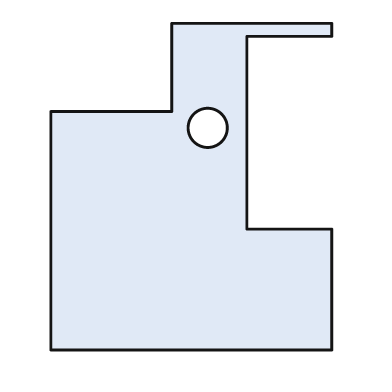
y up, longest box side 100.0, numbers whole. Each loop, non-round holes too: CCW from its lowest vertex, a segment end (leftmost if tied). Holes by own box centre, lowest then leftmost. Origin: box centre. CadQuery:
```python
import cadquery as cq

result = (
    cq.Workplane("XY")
    .moveTo(-43.0, -50.0)
    .lineTo(43.0, -50.0)
    .lineTo(43.0, -13.0)
    .lineTo(17.0, -13.0)
    .lineTo(17.0, 46.0)
    .lineTo(43.0, 46.0)
    .lineTo(43.0, 50.0)
    .lineTo(-6.0, 50.0)
    .lineTo(-6.0, 23.0)
    .lineTo(-43.0, 23.0)
    .close()
    .moveTo(5.0, 18.0)
    .circle(6.0)
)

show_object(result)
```